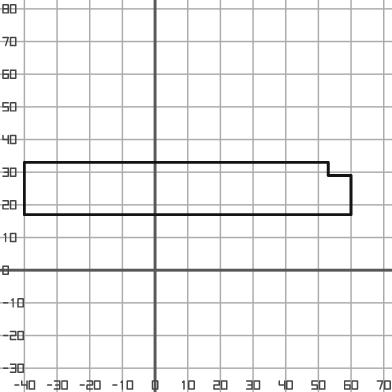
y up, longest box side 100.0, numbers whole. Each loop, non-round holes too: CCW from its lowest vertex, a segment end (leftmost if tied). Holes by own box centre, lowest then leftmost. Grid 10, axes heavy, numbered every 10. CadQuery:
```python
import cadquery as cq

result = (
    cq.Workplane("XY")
    .moveTo(-40.0, 17.0)
    .lineTo(60.0, 17.0)
    .lineTo(60.0, 29.0)
    .lineTo(53.0, 29.0)
    .lineTo(53.0, 33.0)
    .lineTo(-40.0, 33.0)
    .close()
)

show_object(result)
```